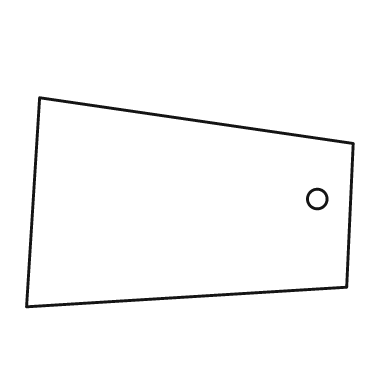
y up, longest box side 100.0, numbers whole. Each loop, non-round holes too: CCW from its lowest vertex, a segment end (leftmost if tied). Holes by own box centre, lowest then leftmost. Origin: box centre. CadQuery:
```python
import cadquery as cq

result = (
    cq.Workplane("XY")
    .moveTo(-50.0, -32.0)
    .lineTo(48.0, -26.0)
    .lineTo(50.0, 18.0)
    .lineTo(-46.0, 32.0)
    .close()
    .moveTo(39.0, 1.0)
    .circle(3.0)
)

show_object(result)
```